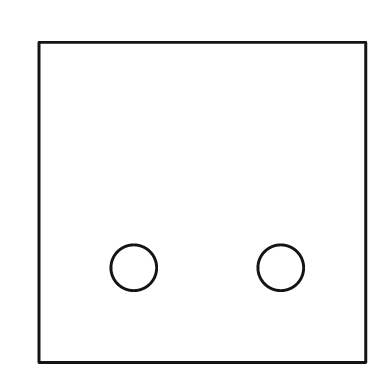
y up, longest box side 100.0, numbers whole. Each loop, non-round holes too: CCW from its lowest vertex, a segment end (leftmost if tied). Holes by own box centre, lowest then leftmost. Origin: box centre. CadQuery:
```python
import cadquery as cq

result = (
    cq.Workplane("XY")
    .moveTo(-50.0, -49.0)
    .lineTo(50.0, -49.0)
    .lineTo(50.0, 49.0)
    .lineTo(-50.0, 49.0)
    .close()
    .moveTo(-21.0, -20.0)
    .circle(7.0)
    .moveTo(24.0, -20.0)
    .circle(7.0)
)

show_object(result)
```